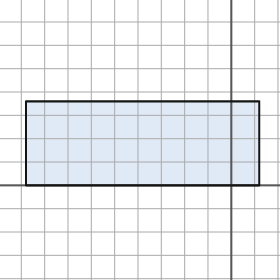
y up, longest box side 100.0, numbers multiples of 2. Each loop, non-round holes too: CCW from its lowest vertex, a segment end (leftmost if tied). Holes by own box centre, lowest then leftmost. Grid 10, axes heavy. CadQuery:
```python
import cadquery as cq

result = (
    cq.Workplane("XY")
    .moveTo(-88.0, 0.0)
    .lineTo(12.0, 0.0)
    .lineTo(12.0, 36.0)
    .lineTo(-88.0, 36.0)
    .close()
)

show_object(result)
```